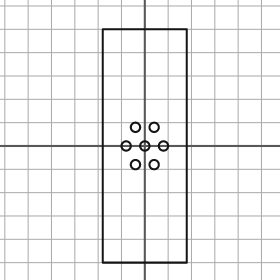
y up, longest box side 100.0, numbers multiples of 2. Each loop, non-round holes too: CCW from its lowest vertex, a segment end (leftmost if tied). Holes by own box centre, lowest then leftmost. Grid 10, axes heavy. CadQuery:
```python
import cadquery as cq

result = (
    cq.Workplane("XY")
    .moveTo(-18.0, -50.0)
    .lineTo(18.0, -50.0)
    .lineTo(18.0, 50.0)
    .lineTo(-18.0, 50.0)
    .close()
    .moveTo(-4.0, -8.0)
    .circle(2.0)
    .moveTo(4.0, -8.0)
    .circle(2.0)
    .moveTo(-8.0, 0.0)
    .circle(2.0)
    .moveTo(0.0, 0.0)
    .circle(2.0)
    .moveTo(8.0, 0.0)
    .circle(2.0)
    .moveTo(-4.0, 8.0)
    .circle(2.0)
    .moveTo(4.0, 8.0)
    .circle(2.0)
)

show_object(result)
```